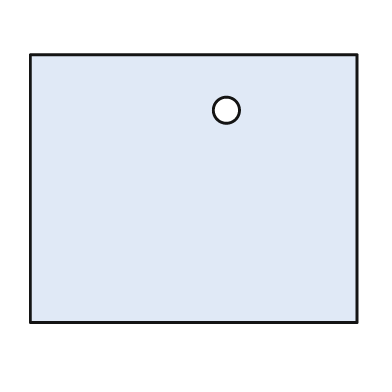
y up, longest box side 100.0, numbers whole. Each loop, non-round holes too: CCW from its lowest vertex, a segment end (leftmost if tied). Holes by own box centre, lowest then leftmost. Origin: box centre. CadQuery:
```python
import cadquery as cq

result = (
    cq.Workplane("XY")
    .moveTo(-50.0, -41.0)
    .lineTo(50.0, -41.0)
    .lineTo(50.0, 41.0)
    .lineTo(-50.0, 41.0)
    .close()
    .moveTo(10.0, 24.0)
    .circle(4.0)
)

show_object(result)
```